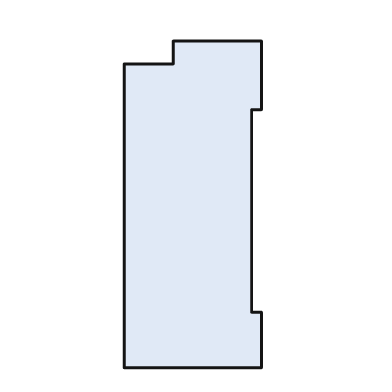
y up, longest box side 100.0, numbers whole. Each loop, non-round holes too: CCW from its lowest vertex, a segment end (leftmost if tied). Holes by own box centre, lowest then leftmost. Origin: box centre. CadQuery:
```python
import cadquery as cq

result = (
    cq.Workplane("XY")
    .moveTo(-21.0, -50.0)
    .lineTo(21.0, -50.0)
    .lineTo(21.0, -33.0)
    .lineTo(18.0, -33.0)
    .lineTo(18.0, 29.0)
    .lineTo(21.0, 29.0)
    .lineTo(21.0, 50.0)
    .lineTo(-6.0, 50.0)
    .lineTo(-6.0, 43.0)
    .lineTo(-21.0, 43.0)
    .close()
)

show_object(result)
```